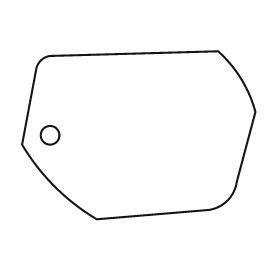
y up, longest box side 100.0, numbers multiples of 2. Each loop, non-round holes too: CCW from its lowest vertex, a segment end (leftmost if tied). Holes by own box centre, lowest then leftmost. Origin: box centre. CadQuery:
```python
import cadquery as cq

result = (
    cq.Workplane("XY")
    .moveTo(-18.0, -36.0)
    .lineTo(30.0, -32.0)
    .threePointArc((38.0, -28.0), (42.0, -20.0))
    .lineTo(50.0, 10.0)
    .threePointArc((44.0, 24.0), (34.0, 36.0))
    .lineTo(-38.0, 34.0)
    .threePointArc((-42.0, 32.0), (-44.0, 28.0))
    .lineTo(-50.0, -4.0)
    .threePointArc((-36.0, -22.0), (-18.0, -36.0))
    .close()
    .moveTo(-38.0, 0.0)
    .circle(4.0)
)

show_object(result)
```